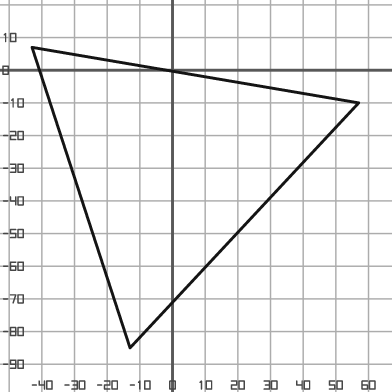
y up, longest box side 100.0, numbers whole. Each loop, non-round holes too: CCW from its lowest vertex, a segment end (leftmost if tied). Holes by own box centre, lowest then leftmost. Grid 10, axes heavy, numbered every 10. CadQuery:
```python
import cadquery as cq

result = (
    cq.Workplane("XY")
    .moveTo(-13.0, -85.0)
    .lineTo(57.0, -10.0)
    .lineTo(-43.0, 7.0)
    .close()
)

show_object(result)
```